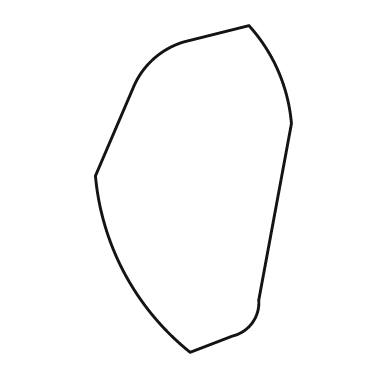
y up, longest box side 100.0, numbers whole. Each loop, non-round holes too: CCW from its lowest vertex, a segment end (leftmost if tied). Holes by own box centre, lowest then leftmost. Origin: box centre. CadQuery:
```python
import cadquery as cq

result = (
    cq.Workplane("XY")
    .moveTo(-1.0, -50.0)
    .lineTo(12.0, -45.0)
    .threePointArc((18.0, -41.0), (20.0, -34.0))
    .lineTo(30.0, 20.0)
    .threePointArc((26.0, 36.0), (17.0, 50.0))
    .lineTo(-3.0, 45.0)
    .threePointArc((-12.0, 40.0), (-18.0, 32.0))
    .lineTo(-30.0, 4.0)
    .threePointArc((-21.0, -26.0), (-1.0, -50.0))
    .close()
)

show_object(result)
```